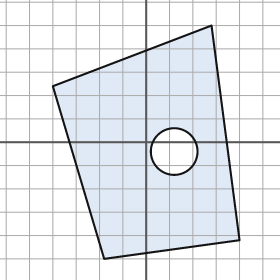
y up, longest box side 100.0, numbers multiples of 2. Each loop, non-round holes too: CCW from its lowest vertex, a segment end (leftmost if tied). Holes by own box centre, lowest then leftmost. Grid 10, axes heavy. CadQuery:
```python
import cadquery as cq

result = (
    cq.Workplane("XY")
    .moveTo(-18.0, -50.0)
    .lineTo(40.0, -42.0)
    .lineTo(28.0, 50.0)
    .lineTo(-40.0, 24.0)
    .close()
    .moveTo(12.0, -4.0)
    .circle(10.0)
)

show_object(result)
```